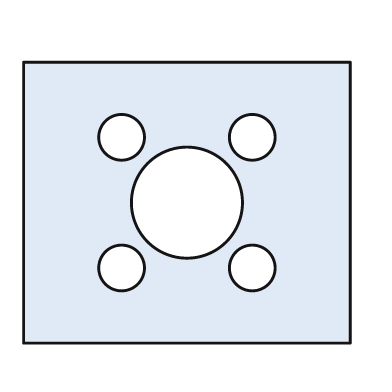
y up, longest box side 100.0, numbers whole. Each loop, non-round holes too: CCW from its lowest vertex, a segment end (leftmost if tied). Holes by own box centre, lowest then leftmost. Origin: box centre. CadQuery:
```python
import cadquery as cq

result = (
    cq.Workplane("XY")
    .moveTo(-50.0, -43.0)
    .lineTo(50.0, -43.0)
    .lineTo(50.0, 43.0)
    .lineTo(-50.0, 43.0)
    .close()
    .moveTo(-20.0, -20.0)
    .circle(7.0)
    .moveTo(20.0, -20.0)
    .circle(7.0)
    .moveTo(0.0, 0.0)
    .circle(17.0)
    .moveTo(-20.0, 20.0)
    .circle(7.0)
    .moveTo(20.0, 20.0)
    .circle(7.0)
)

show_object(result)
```